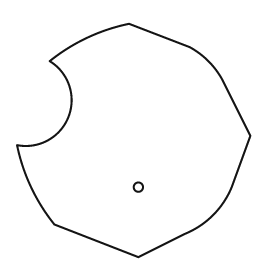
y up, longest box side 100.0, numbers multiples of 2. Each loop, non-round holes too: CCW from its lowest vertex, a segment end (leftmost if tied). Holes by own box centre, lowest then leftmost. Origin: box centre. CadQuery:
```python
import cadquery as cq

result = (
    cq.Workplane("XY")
    .moveTo(2.0, -50.0)
    .lineTo(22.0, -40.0)
    .threePointArc((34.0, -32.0), (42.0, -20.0))
    .lineTo(50.0, 2.0)
    .lineTo(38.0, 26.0)
    .threePointArc((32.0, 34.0), (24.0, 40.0))
    .lineTo(-2.0, 50.0)
    .threePointArc((-20.0, 44.0), (-36.0, 34.0))
    .threePointArc((-28.0, 10.0), (-50.0, -2.0))
    .threePointArc((-44.0, -20.0), (-34.0, -36.0))
    .close()
    .moveTo(2.0, -20.0)
    .circle(2.0)
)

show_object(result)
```